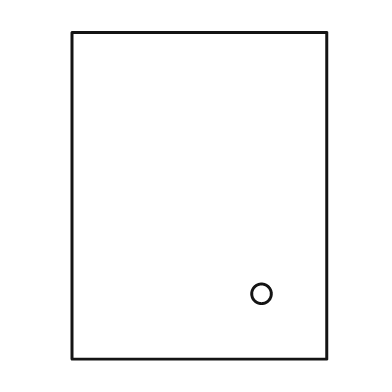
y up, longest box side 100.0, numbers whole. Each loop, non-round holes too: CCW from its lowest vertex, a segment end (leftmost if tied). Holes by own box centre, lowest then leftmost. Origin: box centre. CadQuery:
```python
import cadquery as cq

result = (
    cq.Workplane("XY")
    .moveTo(-39.0, -50.0)
    .lineTo(39.0, -50.0)
    .lineTo(39.0, 50.0)
    .lineTo(-39.0, 50.0)
    .close()
    .moveTo(19.0, -30.0)
    .circle(3.0)
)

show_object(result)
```